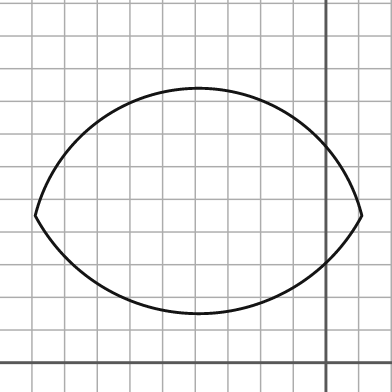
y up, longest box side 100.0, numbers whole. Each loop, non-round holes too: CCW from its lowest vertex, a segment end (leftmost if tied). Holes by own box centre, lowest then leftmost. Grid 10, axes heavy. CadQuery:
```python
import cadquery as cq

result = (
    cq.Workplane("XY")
    .moveTo(-89.0, 45.0)
    .threePointArc((-39.0, 15.0), (11.0, 45.0))
    .threePointArc((-39.0, 84.0), (-89.0, 45.0))
    .close()
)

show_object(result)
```